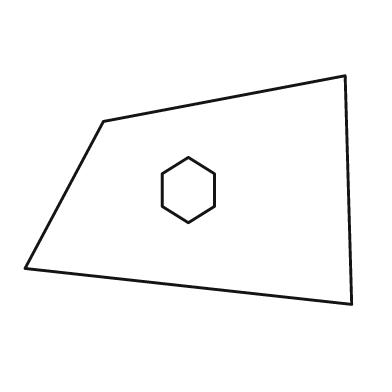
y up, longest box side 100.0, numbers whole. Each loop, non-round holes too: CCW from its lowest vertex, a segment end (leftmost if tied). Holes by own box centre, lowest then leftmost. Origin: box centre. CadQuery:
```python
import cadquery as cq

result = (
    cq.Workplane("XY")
    .moveTo(50.0, -35.0)
    .lineTo(48.0, 35.0)
    .lineTo(-26.0, 21.0)
    .lineTo(-50.0, -24.0)
    .close()
    .moveTo(0.0, -10.0)
    .lineTo(8.0, -5.0)
    .lineTo(8.0, 5.0)
    .lineTo(0.0, 10.0)
    .lineTo(-8.0, 5.0)
    .lineTo(-8.0, -5.0)
    .close()
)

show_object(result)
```